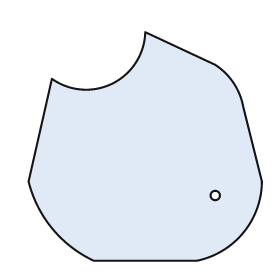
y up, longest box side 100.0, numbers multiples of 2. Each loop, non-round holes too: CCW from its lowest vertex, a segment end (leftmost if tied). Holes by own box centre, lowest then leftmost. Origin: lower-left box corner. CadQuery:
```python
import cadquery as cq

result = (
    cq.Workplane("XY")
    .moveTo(28.0, 0.0)
    .lineTo(72.0, 0.0)
    .threePointArc((92.0, 12.0), (100.0, 34.0))
    .lineTo(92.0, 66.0)
    .threePointArc((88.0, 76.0), (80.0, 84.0))
    .lineTo(50.0, 98.0)
    .threePointArc((36.0, 76.0), (10.0, 78.0))
    .lineTo(0.0, 34.0)
    .threePointArc((10.0, 14.0), (28.0, 0.0))
    .close()
    .moveTo(80.0, 28.0)
    .circle(2.0)
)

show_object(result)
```